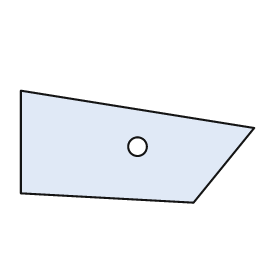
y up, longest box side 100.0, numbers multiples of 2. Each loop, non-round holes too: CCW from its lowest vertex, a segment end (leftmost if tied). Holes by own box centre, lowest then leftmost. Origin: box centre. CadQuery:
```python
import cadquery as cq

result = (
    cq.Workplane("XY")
    .moveTo(24.0, -24.0)
    .lineTo(50.0, 8.0)
    .lineTo(-50.0, 24.0)
    .lineTo(-50.0, -20.0)
    .close()
    .moveTo(0.0, 0.0)
    .circle(4.0)
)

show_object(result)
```